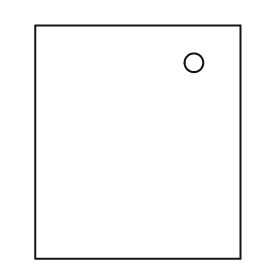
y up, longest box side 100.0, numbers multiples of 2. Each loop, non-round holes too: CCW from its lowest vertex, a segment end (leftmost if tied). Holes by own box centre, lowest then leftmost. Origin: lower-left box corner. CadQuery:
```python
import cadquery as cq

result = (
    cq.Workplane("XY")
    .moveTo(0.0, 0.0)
    .lineTo(88.0, 0.0)
    .lineTo(88.0, 100.0)
    .lineTo(0.0, 100.0)
    .close()
    .moveTo(68.0, 84.0)
    .circle(4.0)
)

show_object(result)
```